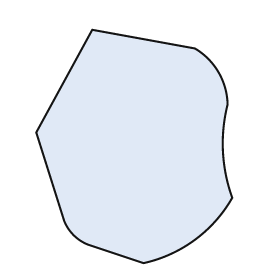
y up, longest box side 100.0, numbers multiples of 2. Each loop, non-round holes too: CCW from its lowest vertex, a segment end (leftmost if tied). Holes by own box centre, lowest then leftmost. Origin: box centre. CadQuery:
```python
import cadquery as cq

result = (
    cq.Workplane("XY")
    .moveTo(4.0, -50.0)
    .threePointArc((26.0, -40.0), (42.0, -22.0))
    .threePointArc((38.0, -2.0), (40.0, 18.0))
    .threePointArc((36.0, 32.0), (26.0, 42.0))
    .lineTo(-18.0, 50.0)
    .lineTo(-42.0, 6.0)
    .lineTo(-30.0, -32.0)
    .threePointArc((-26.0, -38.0), (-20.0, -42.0))
    .close()
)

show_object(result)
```